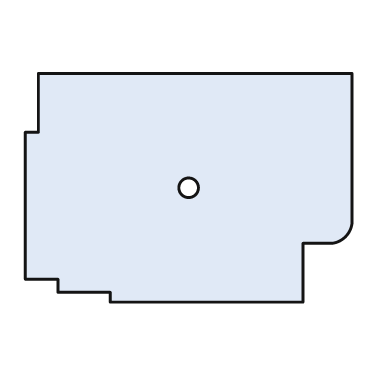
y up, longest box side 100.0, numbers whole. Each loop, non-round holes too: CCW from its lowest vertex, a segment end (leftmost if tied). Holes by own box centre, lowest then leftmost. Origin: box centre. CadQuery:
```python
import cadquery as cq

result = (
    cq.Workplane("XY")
    .moveTo(-24.0, -35.0)
    .lineTo(35.0, -35.0)
    .lineTo(35.0, -17.0)
    .lineTo(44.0, -17.0)
    .threePointArc((48.0, -15.0), (50.0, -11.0))
    .lineTo(50.0, 35.0)
    .lineTo(-46.0, 35.0)
    .lineTo(-46.0, 17.0)
    .lineTo(-50.0, 17.0)
    .lineTo(-50.0, -28.0)
    .lineTo(-40.0, -28.0)
    .lineTo(-40.0, -32.0)
    .lineTo(-24.0, -32.0)
    .close()
    .moveTo(0.0, 0.0)
    .circle(3.0)
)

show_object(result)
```